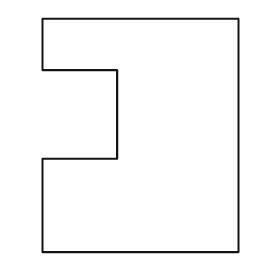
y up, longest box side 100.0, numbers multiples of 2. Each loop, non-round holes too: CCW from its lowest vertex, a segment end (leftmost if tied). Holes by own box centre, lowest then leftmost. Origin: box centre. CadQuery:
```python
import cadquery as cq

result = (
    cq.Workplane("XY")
    .moveTo(-42.0, -50.0)
    .lineTo(42.0, -50.0)
    .lineTo(42.0, 50.0)
    .lineTo(-42.0, 50.0)
    .lineTo(-42.0, 28.0)
    .lineTo(-10.0, 28.0)
    .lineTo(-10.0, -10.0)
    .lineTo(-42.0, -10.0)
    .close()
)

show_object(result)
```